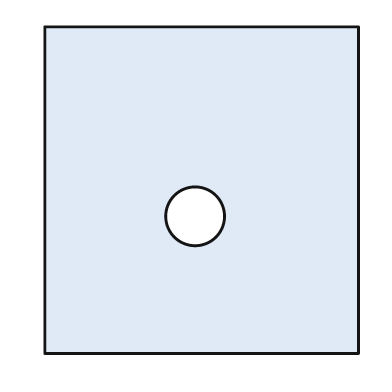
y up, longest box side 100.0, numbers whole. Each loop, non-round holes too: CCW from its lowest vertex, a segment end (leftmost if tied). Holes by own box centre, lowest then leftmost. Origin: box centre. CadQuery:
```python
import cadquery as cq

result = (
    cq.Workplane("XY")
    .moveTo(-48.0, -50.0)
    .lineTo(48.0, -50.0)
    .lineTo(48.0, 50.0)
    .lineTo(-48.0, 50.0)
    .close()
    .moveTo(-2.0, -8.0)
    .circle(9.0)
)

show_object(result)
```